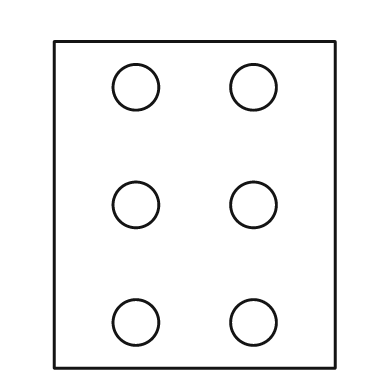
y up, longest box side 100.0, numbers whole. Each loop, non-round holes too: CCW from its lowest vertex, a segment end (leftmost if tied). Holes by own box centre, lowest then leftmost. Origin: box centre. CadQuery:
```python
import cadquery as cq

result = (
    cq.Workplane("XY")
    .moveTo(-43.0, -50.0)
    .lineTo(43.0, -50.0)
    .lineTo(43.0, 50.0)
    .lineTo(-43.0, 50.0)
    .close()
    .moveTo(-18.0, -36.0)
    .circle(7.0)
    .moveTo(18.0, -36.0)
    .circle(7.0)
    .moveTo(-18.0, 0.0)
    .circle(7.0)
    .moveTo(18.0, 0.0)
    .circle(7.0)
    .moveTo(-18.0, 36.0)
    .circle(7.0)
    .moveTo(18.0, 36.0)
    .circle(7.0)
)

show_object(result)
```